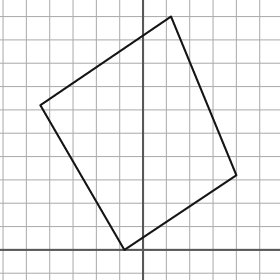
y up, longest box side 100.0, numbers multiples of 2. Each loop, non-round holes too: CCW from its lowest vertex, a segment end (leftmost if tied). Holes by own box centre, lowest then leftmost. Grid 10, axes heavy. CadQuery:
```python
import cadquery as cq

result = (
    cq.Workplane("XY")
    .moveTo(-8.0, 0.0)
    .lineTo(40.0, 32.0)
    .lineTo(12.0, 100.0)
    .lineTo(-44.0, 62.0)
    .close()
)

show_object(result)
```